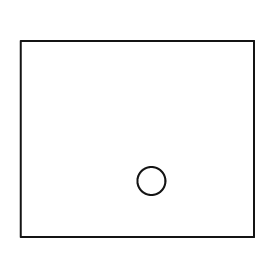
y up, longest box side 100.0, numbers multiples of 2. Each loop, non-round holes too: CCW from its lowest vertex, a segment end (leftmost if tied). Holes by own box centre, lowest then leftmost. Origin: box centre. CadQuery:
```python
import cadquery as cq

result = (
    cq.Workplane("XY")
    .moveTo(-50.0, -42.0)
    .lineTo(50.0, -42.0)
    .lineTo(50.0, 42.0)
    .lineTo(-50.0, 42.0)
    .close()
    .moveTo(6.0, -18.0)
    .circle(6.0)
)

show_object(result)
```